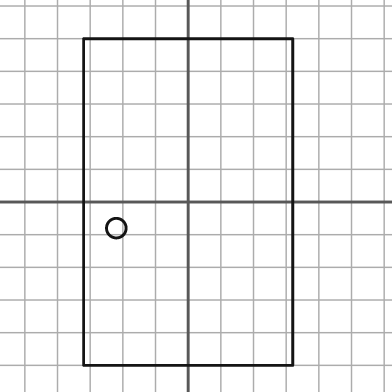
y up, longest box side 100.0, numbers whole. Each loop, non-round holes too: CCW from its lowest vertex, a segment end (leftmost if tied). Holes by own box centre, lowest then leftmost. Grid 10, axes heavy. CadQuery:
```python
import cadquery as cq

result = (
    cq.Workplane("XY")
    .moveTo(-32.0, -50.0)
    .lineTo(32.0, -50.0)
    .lineTo(32.0, 50.0)
    .lineTo(-32.0, 50.0)
    .close()
    .moveTo(-22.0, -8.0)
    .circle(3.0)
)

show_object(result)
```